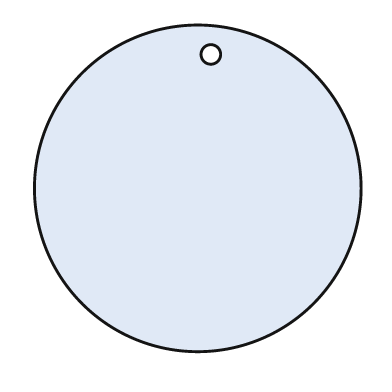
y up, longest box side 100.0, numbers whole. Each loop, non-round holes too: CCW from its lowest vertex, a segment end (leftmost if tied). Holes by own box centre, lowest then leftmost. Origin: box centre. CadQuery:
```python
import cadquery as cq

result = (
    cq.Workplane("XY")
    .moveTo(0.0, 0.0)
    .circle(50.0)
    .moveTo(4.0, 41.0)
    .circle(3.0)
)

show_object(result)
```